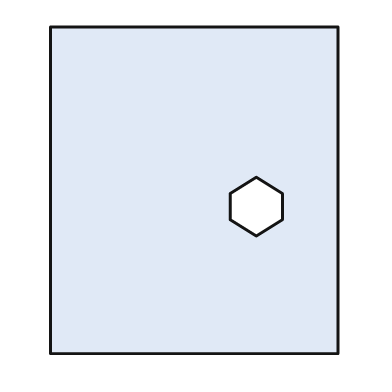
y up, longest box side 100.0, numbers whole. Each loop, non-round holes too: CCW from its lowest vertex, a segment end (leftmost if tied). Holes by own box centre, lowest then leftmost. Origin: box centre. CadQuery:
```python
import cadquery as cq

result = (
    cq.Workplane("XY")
    .moveTo(-44.0, -50.0)
    .lineTo(44.0, -50.0)
    .lineTo(44.0, 50.0)
    .lineTo(-44.0, 50.0)
    .close()
    .moveTo(19.0, -14.0)
    .lineTo(27.0, -9.0)
    .lineTo(27.0, -1.0)
    .lineTo(19.0, 4.0)
    .lineTo(11.0, -1.0)
    .lineTo(11.0, -9.0)
    .close()
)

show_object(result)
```